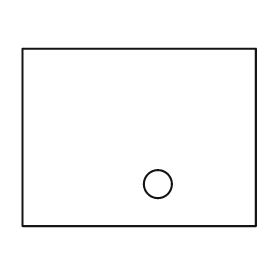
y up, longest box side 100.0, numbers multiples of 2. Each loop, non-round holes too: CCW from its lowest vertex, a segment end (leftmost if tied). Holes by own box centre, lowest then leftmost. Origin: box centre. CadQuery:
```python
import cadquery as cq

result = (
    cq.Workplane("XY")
    .moveTo(-50.0, -38.0)
    .lineTo(50.0, -38.0)
    .lineTo(50.0, 38.0)
    .lineTo(-50.0, 38.0)
    .close()
    .moveTo(8.0, -20.0)
    .circle(6.0)
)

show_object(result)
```